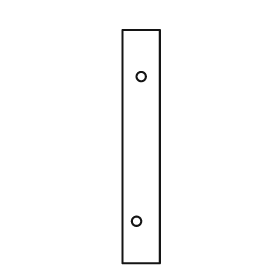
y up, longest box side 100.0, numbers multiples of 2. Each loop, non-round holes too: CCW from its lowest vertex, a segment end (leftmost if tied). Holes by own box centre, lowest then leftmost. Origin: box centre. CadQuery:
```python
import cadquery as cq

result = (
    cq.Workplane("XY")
    .moveTo(-8.0, -50.0)
    .lineTo(8.0, -50.0)
    .lineTo(8.0, 50.0)
    .lineTo(-8.0, 50.0)
    .close()
    .moveTo(-2.0, -32.0)
    .circle(2.0)
    .moveTo(0.0, 30.0)
    .circle(2.0)
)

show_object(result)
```